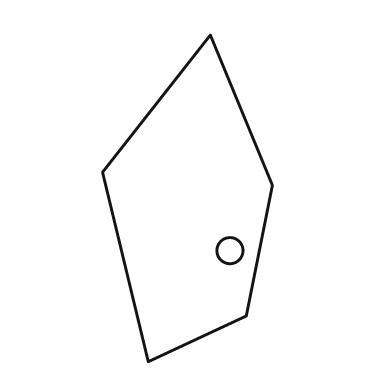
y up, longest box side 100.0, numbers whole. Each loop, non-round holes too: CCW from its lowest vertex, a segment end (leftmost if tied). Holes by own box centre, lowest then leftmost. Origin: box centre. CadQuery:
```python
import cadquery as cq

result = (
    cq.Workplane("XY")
    .moveTo(-12.0, -50.0)
    .lineTo(18.0, -36.0)
    .lineTo(26.0, 4.0)
    .lineTo(7.0, 50.0)
    .lineTo(-26.0, 8.0)
    .close()
    .moveTo(13.0, -16.0)
    .circle(4.0)
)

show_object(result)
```